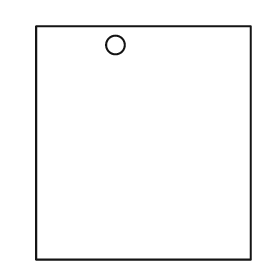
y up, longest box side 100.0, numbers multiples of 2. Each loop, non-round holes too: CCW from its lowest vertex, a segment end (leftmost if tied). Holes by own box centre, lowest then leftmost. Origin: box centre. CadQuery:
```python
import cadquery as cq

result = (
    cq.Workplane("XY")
    .moveTo(-46.0, -50.0)
    .lineTo(46.0, -50.0)
    .lineTo(46.0, 50.0)
    .lineTo(-46.0, 50.0)
    .close()
    .moveTo(-12.0, 42.0)
    .circle(4.0)
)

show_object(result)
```